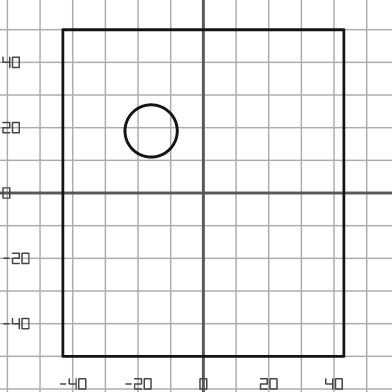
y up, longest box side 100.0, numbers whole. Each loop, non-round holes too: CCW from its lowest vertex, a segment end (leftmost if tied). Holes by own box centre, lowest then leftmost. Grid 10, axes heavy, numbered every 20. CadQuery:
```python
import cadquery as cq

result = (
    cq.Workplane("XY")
    .moveTo(-43.0, -50.0)
    .lineTo(43.0, -50.0)
    .lineTo(43.0, 50.0)
    .lineTo(-43.0, 50.0)
    .close()
    .moveTo(-16.0, 19.0)
    .circle(8.0)
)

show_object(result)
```